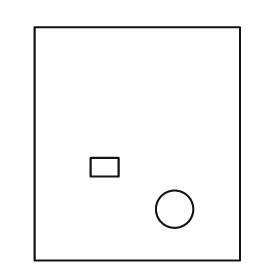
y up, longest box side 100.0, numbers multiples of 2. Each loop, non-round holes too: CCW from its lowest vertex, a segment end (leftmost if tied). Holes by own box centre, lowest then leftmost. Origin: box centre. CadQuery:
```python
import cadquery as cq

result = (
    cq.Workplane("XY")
    .moveTo(-44.0, -50.0)
    .lineTo(44.0, -50.0)
    .lineTo(44.0, 50.0)
    .lineTo(-44.0, 50.0)
    .close()
    .moveTo(16.0, -28.0)
    .circle(8.0)
    .moveTo(-20.0, -14.0)
    .lineTo(-8.0, -14.0)
    .lineTo(-8.0, -6.0)
    .lineTo(-20.0, -6.0)
    .close()
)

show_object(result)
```